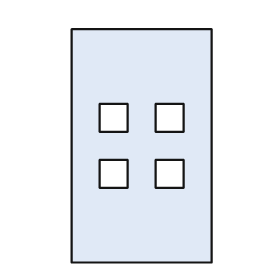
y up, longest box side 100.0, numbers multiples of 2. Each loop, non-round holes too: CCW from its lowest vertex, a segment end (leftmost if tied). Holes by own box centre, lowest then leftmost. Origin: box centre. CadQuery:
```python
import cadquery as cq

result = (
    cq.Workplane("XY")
    .moveTo(-30.0, -50.0)
    .lineTo(30.0, -50.0)
    .lineTo(30.0, 50.0)
    .lineTo(-30.0, 50.0)
    .close()
    .moveTo(-18.0, -18.0)
    .lineTo(-6.0, -18.0)
    .lineTo(-6.0, -6.0)
    .lineTo(-18.0, -6.0)
    .close()
    .moveTo(6.0, -18.0)
    .lineTo(18.0, -18.0)
    .lineTo(18.0, -6.0)
    .lineTo(6.0, -6.0)
    .close()
    .moveTo(-18.0, 6.0)
    .lineTo(-6.0, 6.0)
    .lineTo(-6.0, 18.0)
    .lineTo(-18.0, 18.0)
    .close()
    .moveTo(6.0, 6.0)
    .lineTo(18.0, 6.0)
    .lineTo(18.0, 18.0)
    .lineTo(6.0, 18.0)
    .close()
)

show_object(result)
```